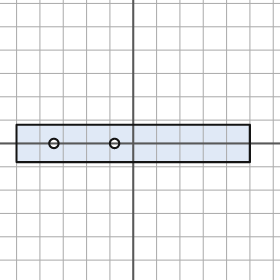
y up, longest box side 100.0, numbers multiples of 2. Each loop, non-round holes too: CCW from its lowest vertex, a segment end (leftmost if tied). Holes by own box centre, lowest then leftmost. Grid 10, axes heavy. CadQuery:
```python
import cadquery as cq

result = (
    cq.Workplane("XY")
    .moveTo(-50.0, -8.0)
    .lineTo(50.0, -8.0)
    .lineTo(50.0, 8.0)
    .lineTo(-50.0, 8.0)
    .close()
    .moveTo(-34.0, 0.0)
    .circle(2.0)
    .moveTo(-8.0, 0.0)
    .circle(2.0)
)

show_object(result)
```